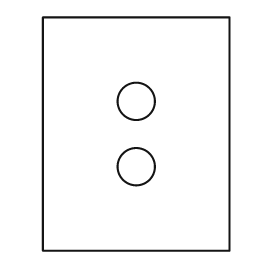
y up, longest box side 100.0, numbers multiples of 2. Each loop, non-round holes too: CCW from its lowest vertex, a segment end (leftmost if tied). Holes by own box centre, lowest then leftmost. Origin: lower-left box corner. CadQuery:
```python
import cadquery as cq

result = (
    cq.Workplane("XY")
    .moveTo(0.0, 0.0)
    .lineTo(80.0, 0.0)
    .lineTo(80.0, 100.0)
    .lineTo(0.0, 100.0)
    .close()
    .moveTo(40.0, 36.0)
    .circle(8.0)
    .moveTo(40.0, 64.0)
    .circle(8.0)
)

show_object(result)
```